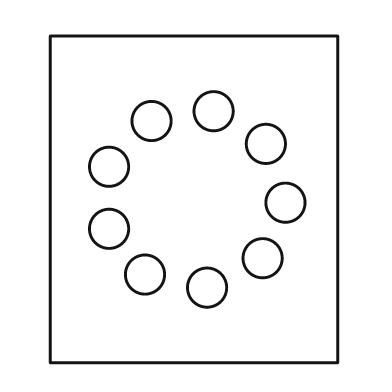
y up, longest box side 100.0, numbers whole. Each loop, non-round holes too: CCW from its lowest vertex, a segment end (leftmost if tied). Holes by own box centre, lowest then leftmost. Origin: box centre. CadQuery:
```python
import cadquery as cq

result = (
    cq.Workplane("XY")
    .moveTo(-44.0, -50.0)
    .lineTo(44.0, -50.0)
    .lineTo(44.0, 50.0)
    .lineTo(-44.0, 50.0)
    .close()
    .moveTo(4.0, -27.0)
    .circle(6.0)
    .moveTo(-15.0, -23.0)
    .circle(6.0)
    .moveTo(21.0, -18.0)
    .circle(6.0)
    .moveTo(-26.0, -9.0)
    .circle(6.0)
    .moveTo(28.0, -1.0)
    .circle(6.0)
    .moveTo(-26.0, 10.0)
    .circle(6.0)
    .moveTo(22.0, 17.0)
    .circle(6.0)
    .moveTo(-13.0, 24.0)
    .circle(6.0)
    .moveTo(6.0, 27.0)
    .circle(6.0)
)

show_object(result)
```